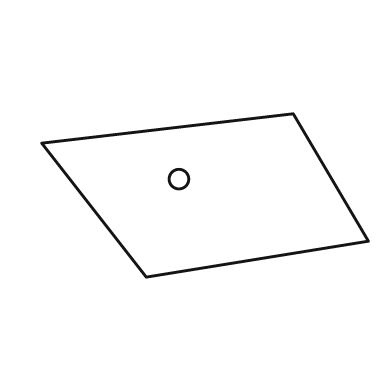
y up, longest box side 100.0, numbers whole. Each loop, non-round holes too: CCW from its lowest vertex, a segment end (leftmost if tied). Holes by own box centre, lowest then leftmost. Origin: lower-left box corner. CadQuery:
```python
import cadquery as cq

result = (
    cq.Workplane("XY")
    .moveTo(32.0, 0.0)
    .lineTo(100.0, 11.0)
    .lineTo(77.0, 50.0)
    .lineTo(0.0, 41.0)
    .close()
    .moveTo(42.0, 30.0)
    .circle(3.0)
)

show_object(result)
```